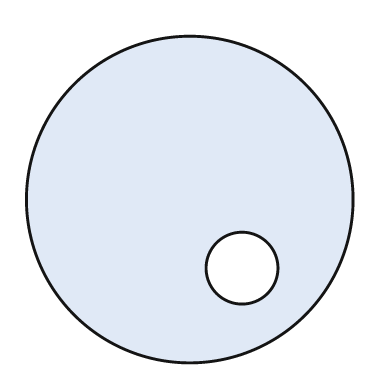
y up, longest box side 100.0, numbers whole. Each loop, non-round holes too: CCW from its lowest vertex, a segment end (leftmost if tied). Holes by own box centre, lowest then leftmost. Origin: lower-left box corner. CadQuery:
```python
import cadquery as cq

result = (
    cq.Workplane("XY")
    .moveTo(50.0, 50.0)
    .circle(50.0)
    .moveTo(66.0, 29.0)
    .circle(11.0)
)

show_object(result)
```